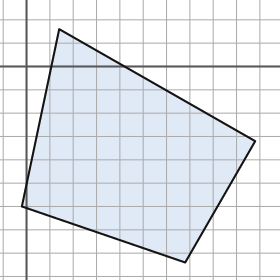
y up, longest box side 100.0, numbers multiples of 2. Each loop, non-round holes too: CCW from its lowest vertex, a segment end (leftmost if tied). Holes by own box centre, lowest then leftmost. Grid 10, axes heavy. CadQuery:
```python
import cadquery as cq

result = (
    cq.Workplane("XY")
    .moveTo(68.0, -84.0)
    .lineTo(98.0, -32.0)
    .lineTo(14.0, 16.0)
    .lineTo(-2.0, -60.0)
    .close()
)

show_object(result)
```